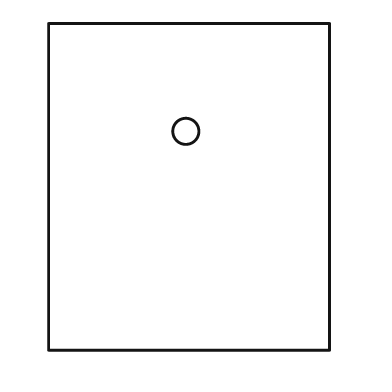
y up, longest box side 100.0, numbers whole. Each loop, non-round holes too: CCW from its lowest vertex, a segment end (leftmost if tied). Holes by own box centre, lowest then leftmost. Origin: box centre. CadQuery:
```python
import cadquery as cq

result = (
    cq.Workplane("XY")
    .moveTo(-43.0, -50.0)
    .lineTo(43.0, -50.0)
    .lineTo(43.0, 50.0)
    .lineTo(-43.0, 50.0)
    .close()
    .moveTo(-1.0, 17.0)
    .circle(4.0)
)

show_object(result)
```